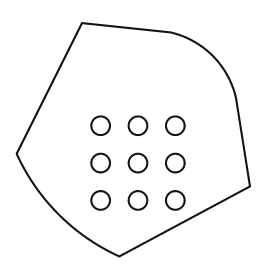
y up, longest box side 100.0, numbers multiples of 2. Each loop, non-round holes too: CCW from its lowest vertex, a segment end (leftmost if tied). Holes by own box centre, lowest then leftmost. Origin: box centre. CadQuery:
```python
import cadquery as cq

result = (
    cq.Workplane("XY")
    .moveTo(-6.0, -50.0)
    .lineTo(50.0, -20.0)
    .lineTo(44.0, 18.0)
    .threePointArc((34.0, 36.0), (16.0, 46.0))
    .lineTo(-22.0, 50.0)
    .lineTo(-50.0, -6.0)
    .threePointArc((-32.0, -32.0), (-6.0, -50.0))
    .close()
    .moveTo(-14.0, -26.0)
    .circle(4.0)
    .moveTo(2.0, -26.0)
    .circle(4.0)
    .moveTo(18.0, -26.0)
    .circle(4.0)
    .moveTo(-14.0, -10.0)
    .circle(4.0)
    .moveTo(2.0, -10.0)
    .circle(4.0)
    .moveTo(18.0, -10.0)
    .circle(4.0)
    .moveTo(-14.0, 6.0)
    .circle(4.0)
    .moveTo(2.0, 6.0)
    .circle(4.0)
    .moveTo(18.0, 6.0)
    .circle(4.0)
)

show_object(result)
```